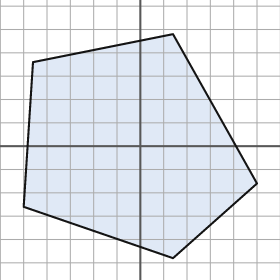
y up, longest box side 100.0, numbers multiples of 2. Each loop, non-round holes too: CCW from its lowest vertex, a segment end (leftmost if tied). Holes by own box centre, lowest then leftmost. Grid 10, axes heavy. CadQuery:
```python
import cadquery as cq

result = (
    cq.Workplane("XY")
    .moveTo(14.0, -48.0)
    .lineTo(50.0, -16.0)
    .lineTo(14.0, 48.0)
    .lineTo(-46.0, 36.0)
    .lineTo(-50.0, -26.0)
    .close()
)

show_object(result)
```